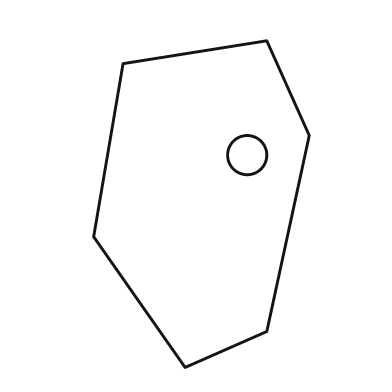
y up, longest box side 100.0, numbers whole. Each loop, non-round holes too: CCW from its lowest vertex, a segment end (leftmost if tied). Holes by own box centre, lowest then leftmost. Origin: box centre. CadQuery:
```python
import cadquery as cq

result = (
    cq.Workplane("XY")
    .moveTo(-5.0, -50.0)
    .lineTo(20.0, -39.0)
    .lineTo(33.0, 21.0)
    .lineTo(20.0, 50.0)
    .lineTo(-24.0, 43.0)
    .lineTo(-33.0, -10.0)
    .close()
    .moveTo(14.0, 15.0)
    .circle(6.0)
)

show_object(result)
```